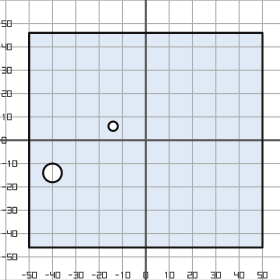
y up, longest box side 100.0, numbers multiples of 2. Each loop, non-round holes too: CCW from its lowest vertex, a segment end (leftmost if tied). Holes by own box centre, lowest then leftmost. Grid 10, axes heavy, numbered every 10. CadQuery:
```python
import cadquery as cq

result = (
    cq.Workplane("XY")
    .moveTo(-50.0, -46.0)
    .lineTo(50.0, -46.0)
    .lineTo(50.0, 46.0)
    .lineTo(-50.0, 46.0)
    .close()
    .moveTo(-40.0, -14.0)
    .circle(4.0)
    .moveTo(-14.0, 6.0)
    .circle(2.0)
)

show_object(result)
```